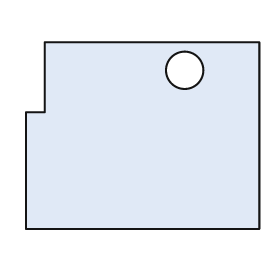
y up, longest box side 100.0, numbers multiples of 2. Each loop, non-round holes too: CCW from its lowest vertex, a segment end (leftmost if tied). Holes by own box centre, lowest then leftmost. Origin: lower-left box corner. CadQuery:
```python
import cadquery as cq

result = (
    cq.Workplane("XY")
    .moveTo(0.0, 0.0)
    .lineTo(100.0, 0.0)
    .lineTo(100.0, 80.0)
    .lineTo(8.0, 80.0)
    .lineTo(8.0, 50.0)
    .lineTo(0.0, 50.0)
    .close()
    .moveTo(68.0, 68.0)
    .circle(8.0)
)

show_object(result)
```